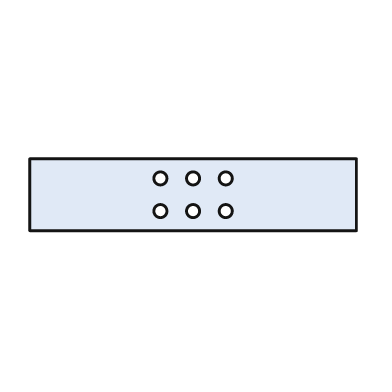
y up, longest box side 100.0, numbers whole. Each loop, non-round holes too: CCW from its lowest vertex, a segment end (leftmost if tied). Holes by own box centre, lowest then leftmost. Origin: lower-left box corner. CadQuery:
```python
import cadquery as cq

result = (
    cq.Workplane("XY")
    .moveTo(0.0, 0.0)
    .lineTo(100.0, 0.0)
    .lineTo(100.0, 22.0)
    .lineTo(0.0, 22.0)
    .close()
    .moveTo(40.0, 6.0)
    .circle(2.0)
    .moveTo(50.0, 6.0)
    .circle(2.0)
    .moveTo(60.0, 6.0)
    .circle(2.0)
    .moveTo(40.0, 16.0)
    .circle(2.0)
    .moveTo(50.0, 16.0)
    .circle(2.0)
    .moveTo(60.0, 16.0)
    .circle(2.0)
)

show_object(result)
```